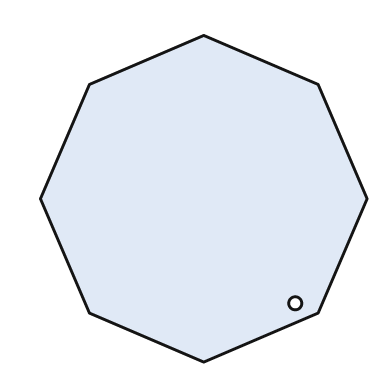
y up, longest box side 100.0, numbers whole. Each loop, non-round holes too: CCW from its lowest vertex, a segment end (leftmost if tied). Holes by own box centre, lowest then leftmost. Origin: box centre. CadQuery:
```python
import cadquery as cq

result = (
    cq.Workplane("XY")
    .moveTo(0.0, -50.0)
    .lineTo(35.0, -35.0)
    .lineTo(50.0, 0.0)
    .lineTo(35.0, 35.0)
    .lineTo(0.0, 50.0)
    .lineTo(-35.0, 35.0)
    .lineTo(-50.0, 0.0)
    .lineTo(-35.0, -35.0)
    .close()
    .moveTo(28.0, -32.0)
    .circle(2.0)
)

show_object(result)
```